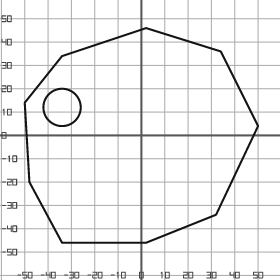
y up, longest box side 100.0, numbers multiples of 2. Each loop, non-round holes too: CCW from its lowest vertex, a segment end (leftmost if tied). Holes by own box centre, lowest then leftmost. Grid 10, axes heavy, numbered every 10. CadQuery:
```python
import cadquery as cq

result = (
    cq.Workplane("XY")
    .moveTo(-34.0, -46.0)
    .lineTo(2.0, -46.0)
    .lineTo(32.0, -34.0)
    .lineTo(50.0, 4.0)
    .lineTo(34.0, 36.0)
    .lineTo(2.0, 46.0)
    .lineTo(-34.0, 34.0)
    .lineTo(-50.0, 14.0)
    .lineTo(-48.0, -20.0)
    .close()
    .moveTo(-34.0, 12.0)
    .circle(8.0)
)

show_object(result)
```